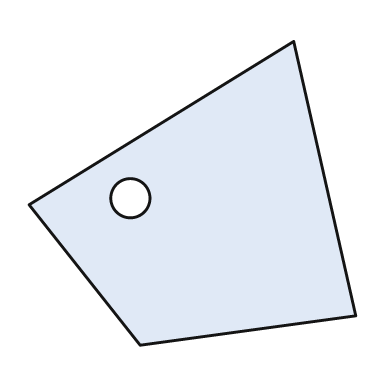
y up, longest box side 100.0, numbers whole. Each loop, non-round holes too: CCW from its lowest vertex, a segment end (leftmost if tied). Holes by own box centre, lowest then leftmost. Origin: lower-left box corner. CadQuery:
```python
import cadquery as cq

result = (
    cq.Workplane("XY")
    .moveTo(34.0, 0.0)
    .lineTo(100.0, 9.0)
    .lineTo(81.0, 93.0)
    .lineTo(0.0, 43.0)
    .close()
    .moveTo(31.0, 45.0)
    .circle(6.0)
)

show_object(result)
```